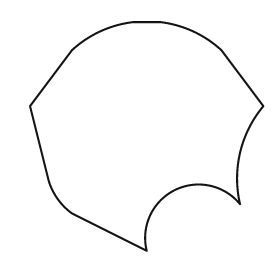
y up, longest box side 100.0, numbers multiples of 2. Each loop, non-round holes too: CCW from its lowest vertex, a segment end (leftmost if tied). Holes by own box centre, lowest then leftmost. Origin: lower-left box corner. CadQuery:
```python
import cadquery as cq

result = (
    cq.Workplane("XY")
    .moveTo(50.0, 0.0)
    .threePointArc((62.0, 26.0), (90.0, 20.0))
    .threePointArc((90.0, 42.0), (100.0, 62.0))
    .lineTo(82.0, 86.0)
    .threePointArc((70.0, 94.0), (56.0, 98.0))
    .lineTo(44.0, 98.0)
    .threePointArc((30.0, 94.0), (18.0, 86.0))
    .lineTo(0.0, 62.0)
    .lineTo(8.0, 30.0)
    .threePointArc((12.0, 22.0), (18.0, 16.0))
    .close()
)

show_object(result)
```